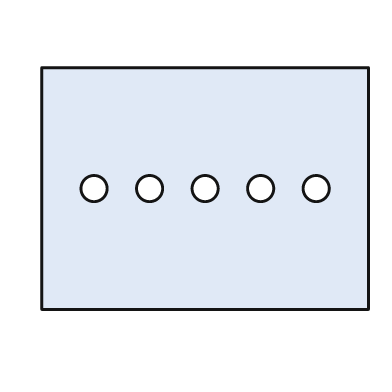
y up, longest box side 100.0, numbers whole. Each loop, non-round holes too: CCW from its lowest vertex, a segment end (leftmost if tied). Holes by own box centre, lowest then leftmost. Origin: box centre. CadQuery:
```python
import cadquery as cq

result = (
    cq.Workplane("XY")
    .moveTo(-50.0, -37.0)
    .lineTo(50.0, -37.0)
    .lineTo(50.0, 37.0)
    .lineTo(-50.0, 37.0)
    .close()
    .moveTo(-34.0, 0.0)
    .circle(4.0)
    .moveTo(-17.0, 0.0)
    .circle(4.0)
    .moveTo(0.0, 0.0)
    .circle(4.0)
    .moveTo(17.0, 0.0)
    .circle(4.0)
    .moveTo(34.0, 0.0)
    .circle(4.0)
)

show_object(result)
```